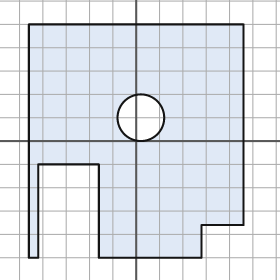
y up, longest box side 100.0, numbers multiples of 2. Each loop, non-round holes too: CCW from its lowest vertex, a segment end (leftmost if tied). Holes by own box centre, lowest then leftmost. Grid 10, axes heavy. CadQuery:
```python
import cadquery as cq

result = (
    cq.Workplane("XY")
    .moveTo(-46.0, -50.0)
    .lineTo(-42.0, -50.0)
    .lineTo(-42.0, -10.0)
    .lineTo(-16.0, -10.0)
    .lineTo(-16.0, -50.0)
    .lineTo(28.0, -50.0)
    .lineTo(28.0, -36.0)
    .lineTo(46.0, -36.0)
    .lineTo(46.0, 50.0)
    .lineTo(-46.0, 50.0)
    .close()
    .moveTo(2.0, 10.0)
    .circle(10.0)
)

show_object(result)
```